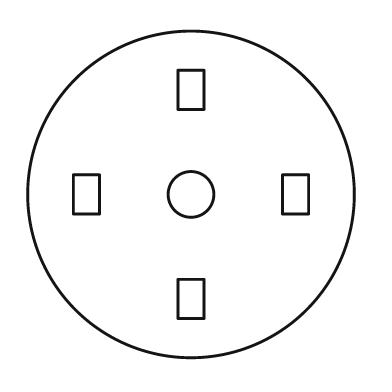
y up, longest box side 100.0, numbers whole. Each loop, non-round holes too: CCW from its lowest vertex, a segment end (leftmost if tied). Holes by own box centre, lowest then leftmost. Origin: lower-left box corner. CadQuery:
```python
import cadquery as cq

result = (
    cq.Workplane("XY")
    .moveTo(50.0, 50.0)
    .circle(50.0)
    .moveTo(46.0, 12.0)
    .lineTo(54.0, 12.0)
    .lineTo(54.0, 24.0)
    .lineTo(46.0, 24.0)
    .close()
    .moveTo(14.0, 44.0)
    .lineTo(22.0, 44.0)
    .lineTo(22.0, 56.0)
    .lineTo(14.0, 56.0)
    .close()
    .moveTo(50.0, 50.0)
    .circle(7.0)
    .moveTo(78.0, 44.0)
    .lineTo(86.0, 44.0)
    .lineTo(86.0, 56.0)
    .lineTo(78.0, 56.0)
    .close()
    .moveTo(46.0, 76.0)
    .lineTo(54.0, 76.0)
    .lineTo(54.0, 88.0)
    .lineTo(46.0, 88.0)
    .close()
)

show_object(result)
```